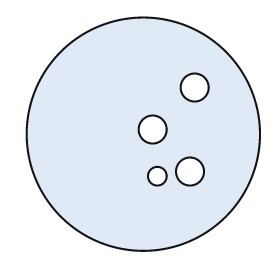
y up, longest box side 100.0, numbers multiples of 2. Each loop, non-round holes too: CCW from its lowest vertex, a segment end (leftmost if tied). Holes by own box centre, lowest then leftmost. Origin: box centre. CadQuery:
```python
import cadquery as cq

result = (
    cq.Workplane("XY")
    .moveTo(0.0, 0.0)
    .circle(50.0)
    .moveTo(6.0, -18.0)
    .circle(4.0)
    .moveTo(20.0, -16.0)
    .circle(6.0)
    .moveTo(4.0, 2.0)
    .circle(6.0)
    .moveTo(22.0, 20.0)
    .circle(6.0)
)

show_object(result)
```